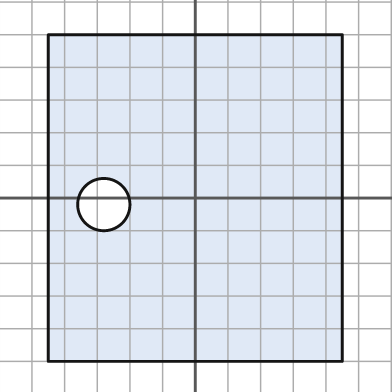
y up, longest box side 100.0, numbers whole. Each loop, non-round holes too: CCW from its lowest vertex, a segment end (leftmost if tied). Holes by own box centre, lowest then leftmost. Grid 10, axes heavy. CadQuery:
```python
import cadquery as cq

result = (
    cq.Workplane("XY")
    .moveTo(-45.0, -50.0)
    .lineTo(45.0, -50.0)
    .lineTo(45.0, 50.0)
    .lineTo(-45.0, 50.0)
    .close()
    .moveTo(-28.0, -2.0)
    .circle(8.0)
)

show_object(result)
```